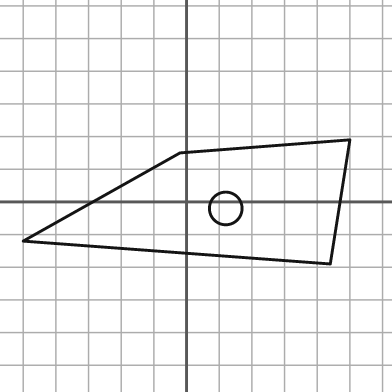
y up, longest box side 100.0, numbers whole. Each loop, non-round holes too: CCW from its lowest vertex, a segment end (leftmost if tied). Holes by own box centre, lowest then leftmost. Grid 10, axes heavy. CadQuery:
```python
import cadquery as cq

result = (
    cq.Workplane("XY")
    .moveTo(44.0, -19.0)
    .lineTo(50.0, 19.0)
    .lineTo(-2.0, 15.0)
    .lineTo(-50.0, -12.0)
    .close()
    .moveTo(12.0, -2.0)
    .circle(5.0)
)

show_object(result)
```